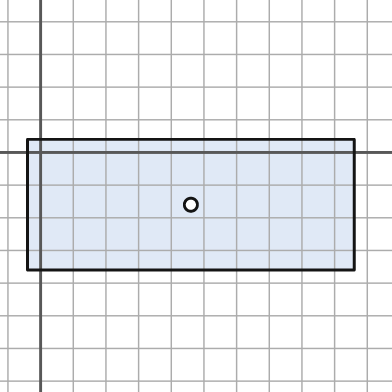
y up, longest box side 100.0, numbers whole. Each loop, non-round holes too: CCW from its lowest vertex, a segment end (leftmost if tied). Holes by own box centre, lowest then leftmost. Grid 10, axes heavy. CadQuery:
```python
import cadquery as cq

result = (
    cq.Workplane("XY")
    .moveTo(-4.0, -36.0)
    .lineTo(96.0, -36.0)
    .lineTo(96.0, 4.0)
    .lineTo(-4.0, 4.0)
    .close()
    .moveTo(46.0, -16.0)
    .circle(2.0)
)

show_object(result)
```